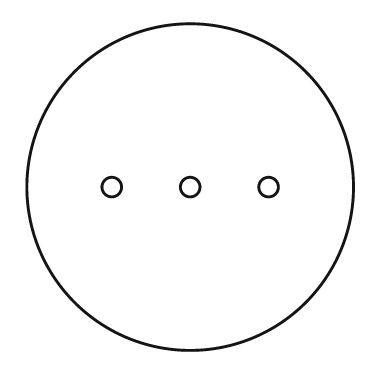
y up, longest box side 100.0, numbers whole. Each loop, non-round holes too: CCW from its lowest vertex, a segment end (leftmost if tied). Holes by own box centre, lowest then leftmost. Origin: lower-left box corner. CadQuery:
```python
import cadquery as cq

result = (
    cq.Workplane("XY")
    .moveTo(50.0, 50.0)
    .circle(50.0)
    .moveTo(26.0, 50.0)
    .circle(3.0)
    .moveTo(50.0, 50.0)
    .circle(3.0)
    .moveTo(74.0, 50.0)
    .circle(3.0)
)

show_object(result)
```